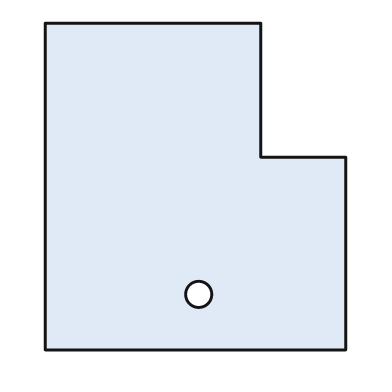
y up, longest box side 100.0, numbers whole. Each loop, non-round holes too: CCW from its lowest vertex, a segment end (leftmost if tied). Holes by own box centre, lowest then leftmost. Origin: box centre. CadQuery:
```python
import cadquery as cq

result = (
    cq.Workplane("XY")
    .moveTo(-46.0, -50.0)
    .lineTo(46.0, -50.0)
    .lineTo(46.0, 9.0)
    .lineTo(20.0, 9.0)
    .lineTo(20.0, 50.0)
    .lineTo(-46.0, 50.0)
    .close()
    .moveTo(1.0, -33.0)
    .circle(4.0)
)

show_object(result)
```